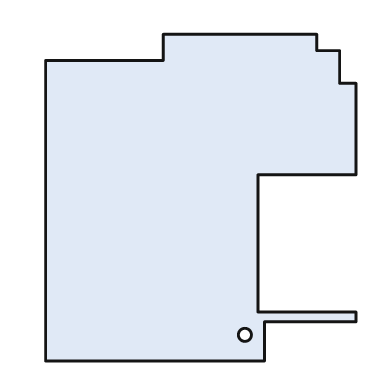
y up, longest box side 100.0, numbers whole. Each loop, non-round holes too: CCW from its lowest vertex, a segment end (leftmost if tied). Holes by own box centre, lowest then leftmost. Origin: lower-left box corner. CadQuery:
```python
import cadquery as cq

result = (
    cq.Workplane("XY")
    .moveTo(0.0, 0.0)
    .lineTo(67.0, 0.0)
    .lineTo(67.0, 12.0)
    .lineTo(95.0, 12.0)
    .lineTo(95.0, 15.0)
    .lineTo(65.0, 15.0)
    .lineTo(65.0, 57.0)
    .lineTo(95.0, 57.0)
    .lineTo(95.0, 85.0)
    .lineTo(90.0, 85.0)
    .lineTo(90.0, 95.0)
    .lineTo(83.0, 95.0)
    .lineTo(83.0, 100.0)
    .lineTo(36.0, 100.0)
    .lineTo(36.0, 92.0)
    .lineTo(0.0, 92.0)
    .close()
    .moveTo(61.0, 8.0)
    .circle(2.0)
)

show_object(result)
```